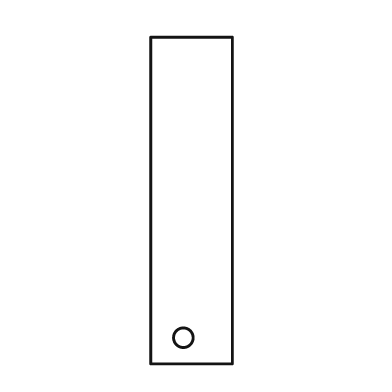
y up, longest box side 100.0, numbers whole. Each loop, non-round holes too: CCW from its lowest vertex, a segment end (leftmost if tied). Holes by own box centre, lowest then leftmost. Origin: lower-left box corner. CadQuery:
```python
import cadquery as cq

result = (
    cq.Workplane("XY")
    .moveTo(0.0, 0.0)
    .lineTo(25.0, 0.0)
    .lineTo(25.0, 100.0)
    .lineTo(0.0, 100.0)
    .close()
    .moveTo(10.0, 8.0)
    .circle(3.0)
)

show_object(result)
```